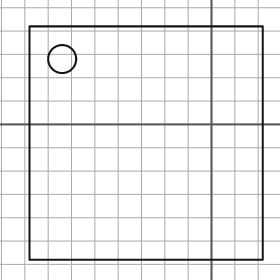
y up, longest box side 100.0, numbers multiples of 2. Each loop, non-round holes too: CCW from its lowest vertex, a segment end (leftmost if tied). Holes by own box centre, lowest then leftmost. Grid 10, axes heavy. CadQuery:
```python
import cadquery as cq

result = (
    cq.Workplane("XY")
    .moveTo(-78.0, -58.0)
    .lineTo(22.0, -58.0)
    .lineTo(22.0, 42.0)
    .lineTo(-78.0, 42.0)
    .close()
    .moveTo(-64.0, 28.0)
    .circle(6.0)
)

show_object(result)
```